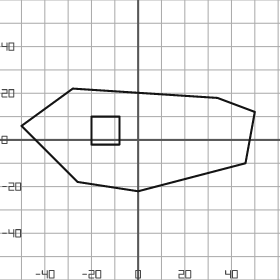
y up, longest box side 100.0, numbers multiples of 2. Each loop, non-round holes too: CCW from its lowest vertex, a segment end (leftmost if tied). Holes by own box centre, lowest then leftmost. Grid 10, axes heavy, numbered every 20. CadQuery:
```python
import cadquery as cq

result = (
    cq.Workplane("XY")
    .moveTo(0.0, -22.0)
    .lineTo(46.0, -10.0)
    .lineTo(50.0, 12.0)
    .lineTo(34.0, 18.0)
    .lineTo(-28.0, 22.0)
    .lineTo(-50.0, 6.0)
    .lineTo(-26.0, -18.0)
    .close()
    .moveTo(-20.0, -2.0)
    .lineTo(-8.0, -2.0)
    .lineTo(-8.0, 10.0)
    .lineTo(-20.0, 10.0)
    .close()
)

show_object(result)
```